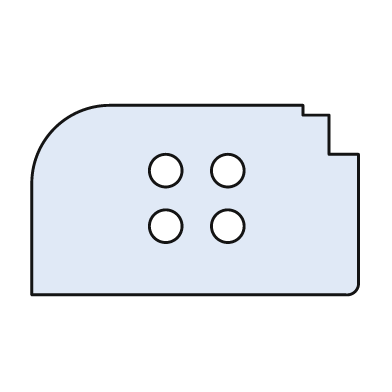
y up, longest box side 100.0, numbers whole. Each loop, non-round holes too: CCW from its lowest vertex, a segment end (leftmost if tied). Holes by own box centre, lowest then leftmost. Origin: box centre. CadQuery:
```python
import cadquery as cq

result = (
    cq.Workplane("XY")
    .moveTo(-50.0, -29.0)
    .lineTo(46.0, -29.0)
    .threePointArc((49.0, -28.0), (50.0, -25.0))
    .lineTo(50.0, 14.0)
    .lineTo(41.0, 14.0)
    .lineTo(41.0, 26.0)
    .lineTo(33.0, 26.0)
    .lineTo(33.0, 29.0)
    .lineTo(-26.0, 29.0)
    .threePointArc((-43.0, 22.0), (-50.0, 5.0))
    .close()
    .moveTo(-9.0, -8.0)
    .circle(5.0)
    .moveTo(10.0, -8.0)
    .circle(5.0)
    .moveTo(-9.0, 9.0)
    .circle(5.0)
    .moveTo(10.0, 9.0)
    .circle(5.0)
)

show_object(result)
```